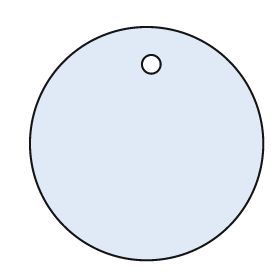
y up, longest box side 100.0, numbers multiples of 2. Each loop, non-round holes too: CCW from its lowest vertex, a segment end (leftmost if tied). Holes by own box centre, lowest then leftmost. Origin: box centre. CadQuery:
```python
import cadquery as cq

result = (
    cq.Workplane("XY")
    .moveTo(0.0, 0.0)
    .circle(50.0)
    .moveTo(2.0, 34.0)
    .circle(4.0)
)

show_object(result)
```